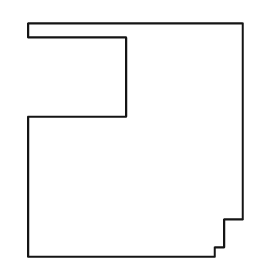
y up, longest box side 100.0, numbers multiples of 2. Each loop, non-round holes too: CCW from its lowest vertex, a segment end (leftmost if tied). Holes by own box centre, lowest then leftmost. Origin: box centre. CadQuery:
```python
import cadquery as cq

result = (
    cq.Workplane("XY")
    .moveTo(-46.0, -50.0)
    .lineTo(34.0, -50.0)
    .lineTo(34.0, -46.0)
    .lineTo(38.0, -46.0)
    .lineTo(38.0, -34.0)
    .lineTo(46.0, -34.0)
    .lineTo(46.0, 50.0)
    .lineTo(-46.0, 50.0)
    .lineTo(-46.0, 44.0)
    .lineTo(-4.0, 44.0)
    .lineTo(-4.0, 10.0)
    .lineTo(-46.0, 10.0)
    .close()
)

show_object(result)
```